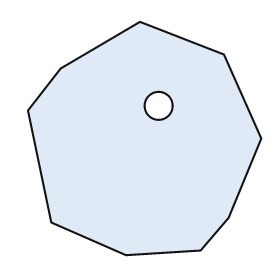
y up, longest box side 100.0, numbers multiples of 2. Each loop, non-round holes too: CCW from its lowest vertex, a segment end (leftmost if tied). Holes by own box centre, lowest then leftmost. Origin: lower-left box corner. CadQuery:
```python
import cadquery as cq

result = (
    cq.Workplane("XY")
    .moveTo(42.0, 0.0)
    .lineTo(74.0, 2.0)
    .lineTo(86.0, 16.0)
    .lineTo(100.0, 50.0)
    .lineTo(84.0, 86.0)
    .lineTo(48.0, 100.0)
    .lineTo(14.0, 80.0)
    .lineTo(0.0, 62.0)
    .lineTo(10.0, 14.0)
    .close()
    .moveTo(56.0, 64.0)
    .circle(6.0)
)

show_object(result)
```